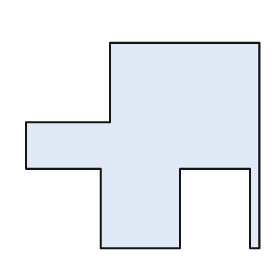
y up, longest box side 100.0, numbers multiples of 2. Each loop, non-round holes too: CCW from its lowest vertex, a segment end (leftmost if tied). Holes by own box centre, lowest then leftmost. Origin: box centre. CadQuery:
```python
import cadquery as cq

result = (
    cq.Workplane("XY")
    .moveTo(-18.0, -44.0)
    .lineTo(16.0, -44.0)
    .lineTo(16.0, -10.0)
    .lineTo(46.0, -10.0)
    .lineTo(46.0, -44.0)
    .lineTo(50.0, -44.0)
    .lineTo(50.0, 44.0)
    .lineTo(-14.0, 44.0)
    .lineTo(-14.0, 10.0)
    .lineTo(-50.0, 10.0)
    .lineTo(-50.0, -10.0)
    .lineTo(-18.0, -10.0)
    .close()
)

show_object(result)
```